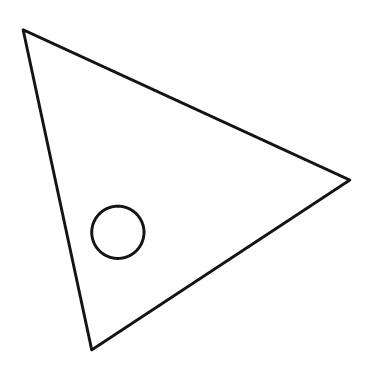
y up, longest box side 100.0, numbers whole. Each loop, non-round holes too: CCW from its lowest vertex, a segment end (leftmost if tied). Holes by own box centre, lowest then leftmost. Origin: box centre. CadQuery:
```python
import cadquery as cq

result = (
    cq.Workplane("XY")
    .moveTo(-29.0, -49.0)
    .lineTo(50.0, 3.0)
    .lineTo(-50.0, 49.0)
    .close()
    .moveTo(-21.0, -13.0)
    .circle(8.0)
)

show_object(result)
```